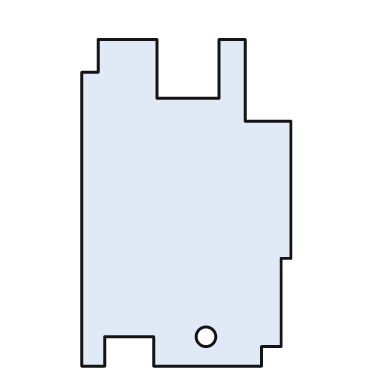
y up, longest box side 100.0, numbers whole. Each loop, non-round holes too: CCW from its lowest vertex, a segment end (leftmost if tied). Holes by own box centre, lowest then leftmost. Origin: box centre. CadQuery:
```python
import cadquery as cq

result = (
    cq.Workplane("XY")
    .moveTo(-32.0, -50.0)
    .lineTo(-25.0, -50.0)
    .lineTo(-25.0, -41.0)
    .lineTo(-10.0, -41.0)
    .lineTo(-10.0, -50.0)
    .lineTo(23.0, -50.0)
    .lineTo(23.0, -44.0)
    .lineTo(29.0, -44.0)
    .lineTo(29.0, -17.0)
    .lineTo(32.0, -17.0)
    .lineTo(32.0, 25.0)
    .lineTo(18.0, 25.0)
    .lineTo(18.0, 50.0)
    .lineTo(10.0, 50.0)
    .lineTo(10.0, 32.0)
    .lineTo(-9.0, 32.0)
    .lineTo(-9.0, 50.0)
    .lineTo(-27.0, 50.0)
    .lineTo(-27.0, 40.0)
    .lineTo(-32.0, 40.0)
    .close()
    .moveTo(6.0, -41.0)
    .circle(3.0)
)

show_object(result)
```